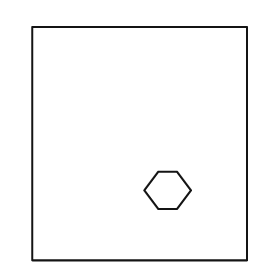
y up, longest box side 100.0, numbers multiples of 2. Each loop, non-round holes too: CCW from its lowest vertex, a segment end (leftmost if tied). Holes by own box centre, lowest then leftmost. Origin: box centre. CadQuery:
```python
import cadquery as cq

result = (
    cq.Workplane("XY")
    .moveTo(-46.0, -50.0)
    .lineTo(46.0, -50.0)
    .lineTo(46.0, 50.0)
    .lineTo(-46.0, 50.0)
    .close()
    .moveTo(8.0, -28.0)
    .lineTo(16.0, -28.0)
    .lineTo(22.0, -20.0)
    .lineTo(16.0, -12.0)
    .lineTo(8.0, -12.0)
    .lineTo(2.0, -20.0)
    .close()
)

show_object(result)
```